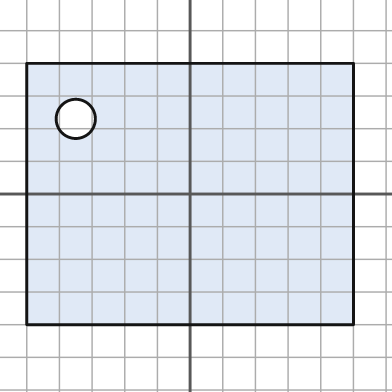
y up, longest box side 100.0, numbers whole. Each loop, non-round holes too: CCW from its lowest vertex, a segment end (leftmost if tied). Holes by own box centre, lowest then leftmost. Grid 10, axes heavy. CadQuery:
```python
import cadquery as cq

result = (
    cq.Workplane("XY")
    .moveTo(-50.0, -40.0)
    .lineTo(50.0, -40.0)
    .lineTo(50.0, 40.0)
    .lineTo(-50.0, 40.0)
    .close()
    .moveTo(-35.0, 23.0)
    .circle(6.0)
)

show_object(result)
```